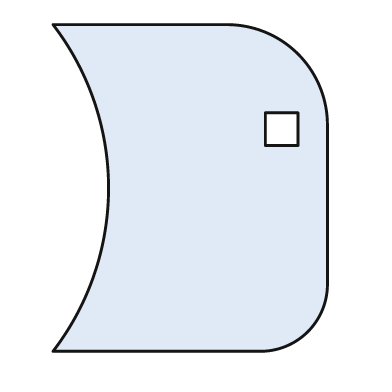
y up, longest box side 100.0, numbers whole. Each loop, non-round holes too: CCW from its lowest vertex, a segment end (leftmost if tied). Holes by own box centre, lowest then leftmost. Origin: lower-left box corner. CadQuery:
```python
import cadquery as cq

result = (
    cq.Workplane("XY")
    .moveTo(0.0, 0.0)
    .lineTo(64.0, 0.0)
    .threePointArc((78.0, 6.0), (84.0, 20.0))
    .lineTo(84.0, 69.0)
    .threePointArc((75.0, 91.0), (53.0, 100.0))
    .lineTo(0.0, 100.0)
    .threePointArc((17.0, 50.0), (0.0, 0.0))
    .close()
    .moveTo(65.0, 63.0)
    .lineTo(75.0, 63.0)
    .lineTo(75.0, 73.0)
    .lineTo(65.0, 73.0)
    .close()
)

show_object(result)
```